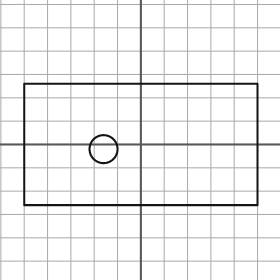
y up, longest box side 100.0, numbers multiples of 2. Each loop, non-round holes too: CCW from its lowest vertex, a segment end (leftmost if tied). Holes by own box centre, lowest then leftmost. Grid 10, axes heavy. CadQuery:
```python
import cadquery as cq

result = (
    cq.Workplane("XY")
    .moveTo(-50.0, -26.0)
    .lineTo(50.0, -26.0)
    .lineTo(50.0, 26.0)
    .lineTo(-50.0, 26.0)
    .close()
    .moveTo(-16.0, -2.0)
    .circle(6.0)
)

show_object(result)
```